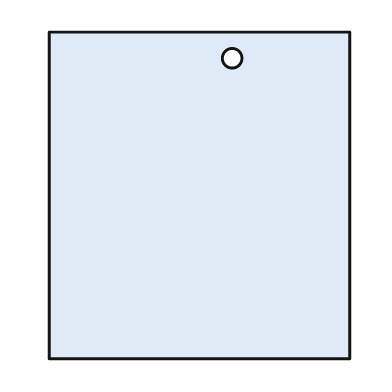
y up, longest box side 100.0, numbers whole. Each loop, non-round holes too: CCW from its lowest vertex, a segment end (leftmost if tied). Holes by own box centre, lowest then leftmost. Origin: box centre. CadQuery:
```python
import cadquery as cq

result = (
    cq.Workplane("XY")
    .moveTo(-46.0, -50.0)
    .lineTo(46.0, -50.0)
    .lineTo(46.0, 50.0)
    .lineTo(-46.0, 50.0)
    .close()
    .moveTo(10.0, 42.0)
    .circle(3.0)
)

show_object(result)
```